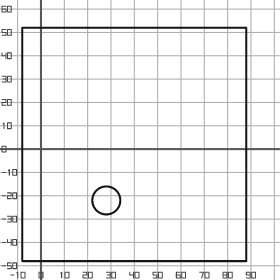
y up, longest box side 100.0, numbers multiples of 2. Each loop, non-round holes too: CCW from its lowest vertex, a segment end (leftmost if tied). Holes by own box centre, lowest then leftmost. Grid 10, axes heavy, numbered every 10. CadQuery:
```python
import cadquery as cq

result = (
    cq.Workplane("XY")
    .moveTo(-8.0, -48.0)
    .lineTo(88.0, -48.0)
    .lineTo(88.0, 52.0)
    .lineTo(-8.0, 52.0)
    .close()
    .moveTo(28.0, -22.0)
    .circle(6.0)
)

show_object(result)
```